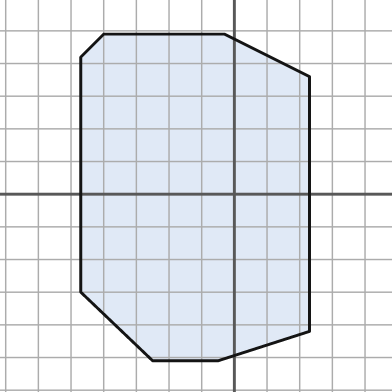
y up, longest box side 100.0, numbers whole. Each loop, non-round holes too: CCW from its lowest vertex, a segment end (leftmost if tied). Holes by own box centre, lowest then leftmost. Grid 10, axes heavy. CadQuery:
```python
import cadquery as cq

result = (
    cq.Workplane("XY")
    .moveTo(-25.0, -51.0)
    .lineTo(-5.0, -51.0)
    .lineTo(23.0, -42.0)
    .lineTo(23.0, 36.0)
    .lineTo(-3.0, 49.0)
    .lineTo(-40.0, 49.0)
    .lineTo(-47.0, 42.0)
    .lineTo(-47.0, -30.0)
    .close()
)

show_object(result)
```